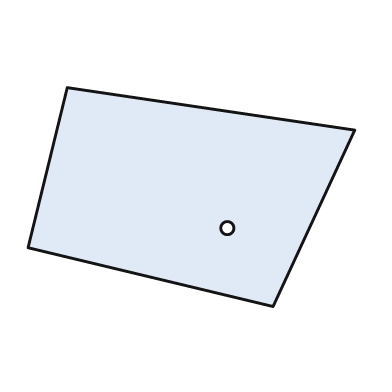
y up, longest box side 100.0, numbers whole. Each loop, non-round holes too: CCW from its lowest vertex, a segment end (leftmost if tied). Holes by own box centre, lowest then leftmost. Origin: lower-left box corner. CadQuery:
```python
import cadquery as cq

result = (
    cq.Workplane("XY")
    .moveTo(75.0, 0.0)
    .lineTo(100.0, 54.0)
    .lineTo(12.0, 67.0)
    .lineTo(0.0, 18.0)
    .close()
    .moveTo(61.0, 24.0)
    .circle(2.0)
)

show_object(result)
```